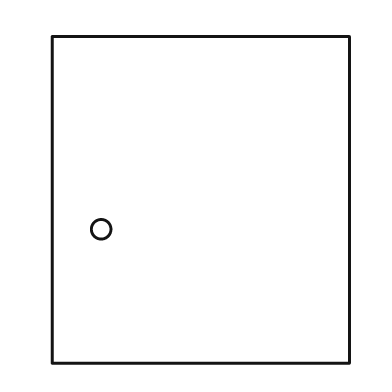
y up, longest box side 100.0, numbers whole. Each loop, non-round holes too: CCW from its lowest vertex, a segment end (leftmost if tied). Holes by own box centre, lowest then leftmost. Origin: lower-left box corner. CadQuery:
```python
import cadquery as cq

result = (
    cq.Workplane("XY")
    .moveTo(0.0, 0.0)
    .lineTo(91.0, 0.0)
    .lineTo(91.0, 100.0)
    .lineTo(0.0, 100.0)
    .close()
    .moveTo(15.0, 41.0)
    .circle(3.0)
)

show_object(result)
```